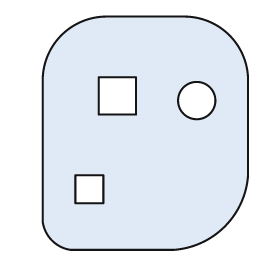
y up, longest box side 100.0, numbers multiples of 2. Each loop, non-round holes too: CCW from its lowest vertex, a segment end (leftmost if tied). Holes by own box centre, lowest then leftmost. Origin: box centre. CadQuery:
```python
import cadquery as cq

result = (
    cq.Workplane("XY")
    .moveTo(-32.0, -50.0)
    .lineTo(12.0, -50.0)
    .threePointArc((34.0, -40.0), (44.0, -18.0))
    .lineTo(44.0, 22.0)
    .threePointArc((36.0, 42.0), (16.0, 50.0))
    .lineTo(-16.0, 50.0)
    .threePointArc((-36.0, 42.0), (-44.0, 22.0))
    .lineTo(-44.0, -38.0)
    .threePointArc((-40.0, -46.0), (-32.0, -50.0))
    .close()
    .moveTo(-30.0, -30.0)
    .lineTo(-18.0, -30.0)
    .lineTo(-18.0, -18.0)
    .lineTo(-30.0, -18.0)
    .close()
    .moveTo(22.0, 14.0)
    .circle(8.0)
    .moveTo(-20.0, 8.0)
    .lineTo(-4.0, 8.0)
    .lineTo(-4.0, 24.0)
    .lineTo(-20.0, 24.0)
    .close()
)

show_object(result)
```